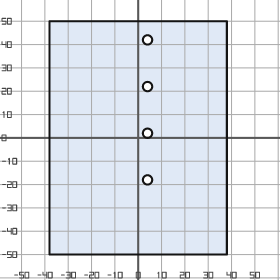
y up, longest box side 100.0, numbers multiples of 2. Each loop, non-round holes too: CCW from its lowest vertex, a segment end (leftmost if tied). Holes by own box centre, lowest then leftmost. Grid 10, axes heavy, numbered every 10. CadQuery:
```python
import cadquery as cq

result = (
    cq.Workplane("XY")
    .moveTo(-38.0, -50.0)
    .lineTo(38.0, -50.0)
    .lineTo(38.0, 50.0)
    .lineTo(-38.0, 50.0)
    .close()
    .moveTo(4.0, -18.0)
    .circle(2.0)
    .moveTo(4.0, 2.0)
    .circle(2.0)
    .moveTo(4.0, 22.0)
    .circle(2.0)
    .moveTo(4.0, 42.0)
    .circle(2.0)
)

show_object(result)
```